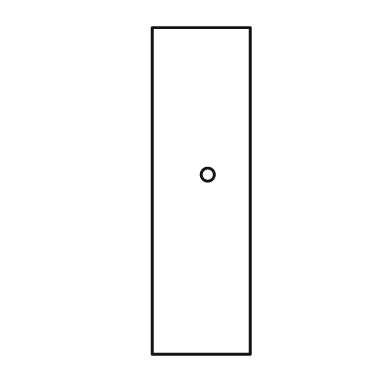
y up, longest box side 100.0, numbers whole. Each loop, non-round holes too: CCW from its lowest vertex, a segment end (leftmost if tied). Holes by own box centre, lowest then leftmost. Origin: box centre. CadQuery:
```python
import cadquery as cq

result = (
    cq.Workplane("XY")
    .moveTo(-15.0, -50.0)
    .lineTo(15.0, -50.0)
    .lineTo(15.0, 50.0)
    .lineTo(-15.0, 50.0)
    .close()
    .moveTo(2.0, 5.0)
    .circle(2.0)
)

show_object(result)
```